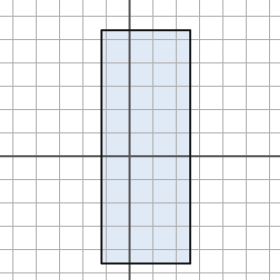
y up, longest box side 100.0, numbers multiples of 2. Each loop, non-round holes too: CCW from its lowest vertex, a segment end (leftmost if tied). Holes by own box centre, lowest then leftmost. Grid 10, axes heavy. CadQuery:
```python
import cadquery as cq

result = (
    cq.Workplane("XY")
    .moveTo(-12.0, -46.0)
    .lineTo(26.0, -46.0)
    .lineTo(26.0, 54.0)
    .lineTo(-12.0, 54.0)
    .close()
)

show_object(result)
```